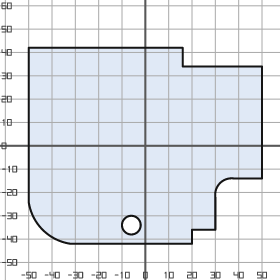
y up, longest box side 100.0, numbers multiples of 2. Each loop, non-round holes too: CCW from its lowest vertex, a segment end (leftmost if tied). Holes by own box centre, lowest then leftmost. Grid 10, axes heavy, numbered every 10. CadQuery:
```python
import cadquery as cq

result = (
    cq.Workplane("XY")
    .moveTo(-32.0, -42.0)
    .lineTo(20.0, -42.0)
    .lineTo(20.0, -36.0)
    .lineTo(30.0, -36.0)
    .lineTo(30.0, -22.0)
    .threePointArc((32.0, -16.0), (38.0, -14.0))
    .lineTo(50.0, -14.0)
    .lineTo(50.0, 34.0)
    .lineTo(16.0, 34.0)
    .lineTo(16.0, 42.0)
    .lineTo(-50.0, 42.0)
    .lineTo(-50.0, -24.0)
    .threePointArc((-44.0, -36.0), (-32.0, -42.0))
    .close()
    .moveTo(-6.0, -34.0)
    .circle(4.0)
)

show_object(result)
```